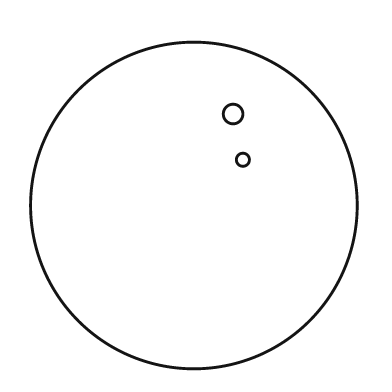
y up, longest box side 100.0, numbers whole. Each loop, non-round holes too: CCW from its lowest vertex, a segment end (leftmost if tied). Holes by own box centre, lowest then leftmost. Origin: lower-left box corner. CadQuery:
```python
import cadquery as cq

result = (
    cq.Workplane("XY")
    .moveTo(50.0, 50.0)
    .circle(50.0)
    .moveTo(65.0, 64.0)
    .circle(2.0)
    .moveTo(62.0, 78.0)
    .circle(3.0)
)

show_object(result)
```